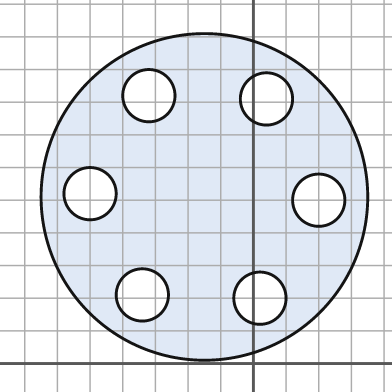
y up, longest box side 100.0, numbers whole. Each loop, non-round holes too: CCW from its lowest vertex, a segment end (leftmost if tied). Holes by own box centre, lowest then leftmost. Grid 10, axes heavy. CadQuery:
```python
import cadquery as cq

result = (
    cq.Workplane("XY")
    .moveTo(-15.0, 51.0)
    .circle(50.0)
    .moveTo(2.0, 20.0)
    .circle(8.0)
    .moveTo(-34.0, 21.0)
    .circle(8.0)
    .moveTo(20.0, 50.0)
    .circle(8.0)
    .moveTo(-50.0, 52.0)
    .circle(8.0)
    .moveTo(4.0, 81.0)
    .circle(8.0)
    .moveTo(-32.0, 82.0)
    .circle(8.0)
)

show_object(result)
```